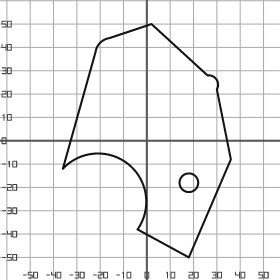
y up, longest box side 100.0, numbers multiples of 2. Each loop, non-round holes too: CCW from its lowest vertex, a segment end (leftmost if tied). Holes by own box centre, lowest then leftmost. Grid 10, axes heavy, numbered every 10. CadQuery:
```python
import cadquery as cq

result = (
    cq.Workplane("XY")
    .moveTo(18.0, -50.0)
    .lineTo(36.0, -8.0)
    .lineTo(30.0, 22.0)
    .threePointArc((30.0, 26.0), (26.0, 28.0))
    .lineTo(2.0, 50.0)
    .lineTo(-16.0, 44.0)
    .threePointArc((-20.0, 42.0), (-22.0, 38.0))
    .lineTo(-36.0, -12.0)
    .threePointArc((-8.0, -10.0), (-4.0, -38.0))
    .close()
    .moveTo(18.0, -18.0)
    .circle(4.0)
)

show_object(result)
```